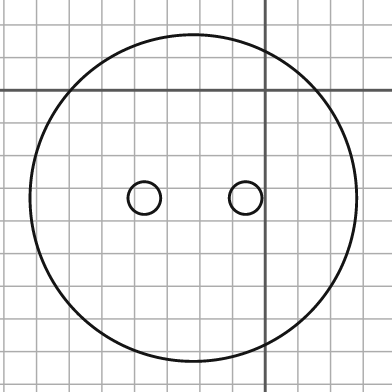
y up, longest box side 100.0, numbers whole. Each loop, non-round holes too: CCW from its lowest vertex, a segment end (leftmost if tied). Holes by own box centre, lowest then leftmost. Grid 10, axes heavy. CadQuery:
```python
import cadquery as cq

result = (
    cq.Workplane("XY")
    .moveTo(-22.0, -33.0)
    .circle(50.0)
    .moveTo(-37.0, -33.0)
    .circle(5.0)
    .moveTo(-6.0, -33.0)
    .circle(5.0)
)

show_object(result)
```